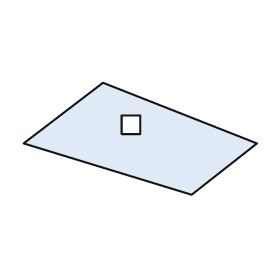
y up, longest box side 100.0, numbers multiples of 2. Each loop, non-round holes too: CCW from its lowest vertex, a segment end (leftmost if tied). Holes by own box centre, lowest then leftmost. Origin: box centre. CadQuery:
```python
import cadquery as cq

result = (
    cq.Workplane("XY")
    .moveTo(22.0, -24.0)
    .lineTo(50.0, -2.0)
    .lineTo(-16.0, 24.0)
    .lineTo(-50.0, -2.0)
    .close()
    .moveTo(-8.0, 2.0)
    .lineTo(0.0, 2.0)
    .lineTo(0.0, 10.0)
    .lineTo(-8.0, 10.0)
    .close()
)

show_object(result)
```